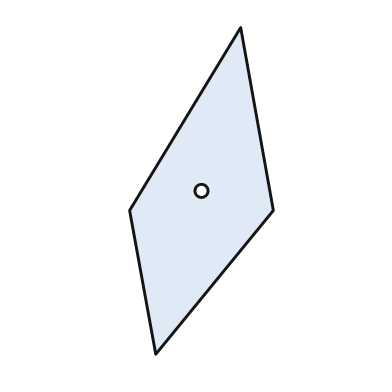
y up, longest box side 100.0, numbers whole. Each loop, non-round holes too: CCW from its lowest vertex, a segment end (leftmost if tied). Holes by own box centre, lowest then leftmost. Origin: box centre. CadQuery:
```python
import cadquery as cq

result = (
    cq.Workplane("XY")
    .moveTo(-14.0, -50.0)
    .lineTo(22.0, -6.0)
    .lineTo(12.0, 50.0)
    .lineTo(-22.0, -6.0)
    .close()
    .moveTo(0.0, 0.0)
    .circle(2.0)
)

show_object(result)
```